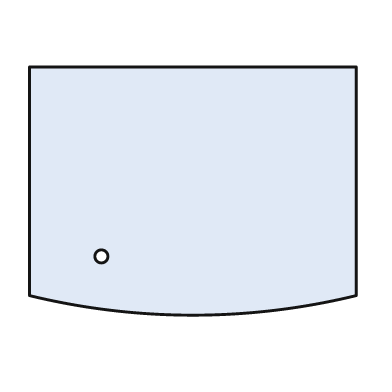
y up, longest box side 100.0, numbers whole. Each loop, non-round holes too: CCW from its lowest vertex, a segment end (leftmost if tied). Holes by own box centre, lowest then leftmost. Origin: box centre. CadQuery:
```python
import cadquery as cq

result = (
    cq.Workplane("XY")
    .moveTo(-50.0, -32.0)
    .threePointArc((0.0, -38.0), (50.0, -32.0))
    .lineTo(50.0, 38.0)
    .lineTo(-50.0, 38.0)
    .close()
    .moveTo(-28.0, -20.0)
    .circle(2.0)
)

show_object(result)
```